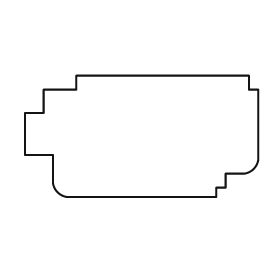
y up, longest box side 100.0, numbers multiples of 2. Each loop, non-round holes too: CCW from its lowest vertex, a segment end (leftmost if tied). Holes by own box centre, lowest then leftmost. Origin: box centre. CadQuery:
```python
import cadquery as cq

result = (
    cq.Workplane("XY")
    .moveTo(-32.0, -26.0)
    .lineTo(32.0, -26.0)
    .lineTo(32.0, -22.0)
    .lineTo(36.0, -22.0)
    .lineTo(36.0, -16.0)
    .lineTo(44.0, -16.0)
    .threePointArc((48.0, -14.0), (50.0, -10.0))
    .lineTo(50.0, 20.0)
    .lineTo(46.0, 20.0)
    .lineTo(46.0, 26.0)
    .lineTo(-28.0, 26.0)
    .lineTo(-28.0, 20.0)
    .lineTo(-42.0, 20.0)
    .lineTo(-42.0, 10.0)
    .lineTo(-50.0, 10.0)
    .lineTo(-50.0, -8.0)
    .lineTo(-38.0, -8.0)
    .lineTo(-38.0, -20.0)
    .threePointArc((-36.0, -24.0), (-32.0, -26.0))
    .close()
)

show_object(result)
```